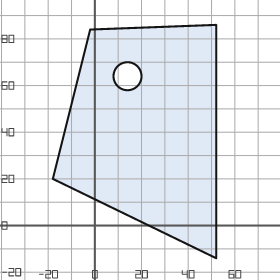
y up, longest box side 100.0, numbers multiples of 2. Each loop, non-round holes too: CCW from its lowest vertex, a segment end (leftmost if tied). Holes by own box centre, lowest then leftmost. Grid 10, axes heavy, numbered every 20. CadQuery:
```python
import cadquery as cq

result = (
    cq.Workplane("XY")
    .moveTo(52.0, -14.0)
    .lineTo(52.0, 86.0)
    .lineTo(-2.0, 84.0)
    .lineTo(-18.0, 20.0)
    .close()
    .moveTo(14.0, 64.0)
    .circle(6.0)
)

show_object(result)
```